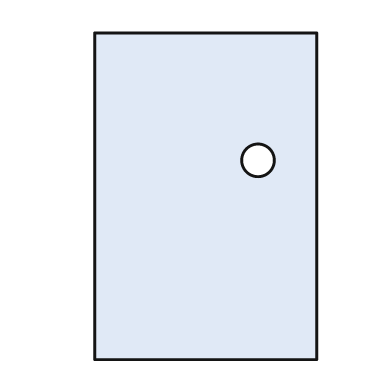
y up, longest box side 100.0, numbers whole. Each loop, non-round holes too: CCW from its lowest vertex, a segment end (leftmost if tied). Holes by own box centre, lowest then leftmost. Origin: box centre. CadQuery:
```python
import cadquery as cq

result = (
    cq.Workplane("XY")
    .moveTo(-34.0, -50.0)
    .lineTo(34.0, -50.0)
    .lineTo(34.0, 50.0)
    .lineTo(-34.0, 50.0)
    .close()
    .moveTo(16.0, 11.0)
    .circle(5.0)
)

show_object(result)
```